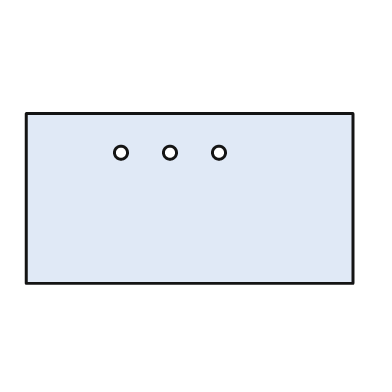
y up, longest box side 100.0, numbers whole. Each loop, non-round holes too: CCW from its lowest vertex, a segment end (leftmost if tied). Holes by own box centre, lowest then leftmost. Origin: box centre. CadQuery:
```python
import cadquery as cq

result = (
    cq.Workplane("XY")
    .moveTo(-50.0, -26.0)
    .lineTo(50.0, -26.0)
    .lineTo(50.0, 26.0)
    .lineTo(-50.0, 26.0)
    .close()
    .moveTo(-21.0, 14.0)
    .circle(2.0)
    .moveTo(-6.0, 14.0)
    .circle(2.0)
    .moveTo(9.0, 14.0)
    .circle(2.0)
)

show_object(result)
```